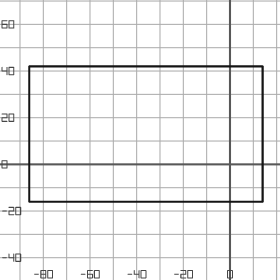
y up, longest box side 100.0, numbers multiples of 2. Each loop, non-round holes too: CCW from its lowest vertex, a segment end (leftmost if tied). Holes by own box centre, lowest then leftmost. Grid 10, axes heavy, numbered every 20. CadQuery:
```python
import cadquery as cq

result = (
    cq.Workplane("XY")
    .moveTo(-86.0, -16.0)
    .lineTo(14.0, -16.0)
    .lineTo(14.0, 42.0)
    .lineTo(-86.0, 42.0)
    .close()
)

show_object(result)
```